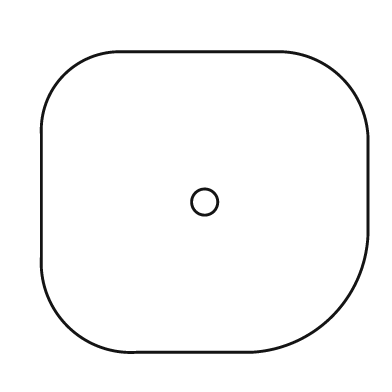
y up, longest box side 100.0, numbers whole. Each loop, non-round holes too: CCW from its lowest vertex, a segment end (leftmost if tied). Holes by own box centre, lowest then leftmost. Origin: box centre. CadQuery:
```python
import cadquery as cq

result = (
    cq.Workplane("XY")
    .moveTo(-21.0, -46.0)
    .lineTo(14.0, -46.0)
    .threePointArc((39.0, -35.0), (50.0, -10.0))
    .lineTo(50.0, 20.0)
    .threePointArc((42.0, 38.0), (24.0, 46.0))
    .lineTo(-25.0, 46.0)
    .threePointArc((-43.0, 39.0), (-50.0, 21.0))
    .lineTo(-50.0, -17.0)
    .threePointArc((-42.0, -38.0), (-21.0, -46.0))
    .close()
    .moveTo(0.0, 0.0)
    .circle(4.0)
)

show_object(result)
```